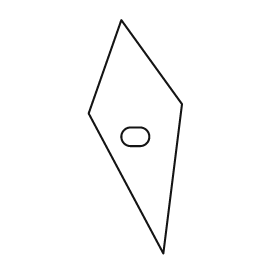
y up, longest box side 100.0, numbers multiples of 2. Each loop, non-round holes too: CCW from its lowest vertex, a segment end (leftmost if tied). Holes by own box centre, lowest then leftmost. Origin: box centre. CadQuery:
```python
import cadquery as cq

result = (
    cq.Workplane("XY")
    .moveTo(12.0, -50.0)
    .lineTo(20.0, 14.0)
    .lineTo(-6.0, 50.0)
    .lineTo(-20.0, 10.0)
    .close()
    .moveTo(-2.0, -4.0)
    .lineTo(2.0, -4.0)
    .threePointArc((6.0, 0.0), (2.0, 4.0))
    .lineTo(-2.0, 4.0)
    .threePointArc((-6.0, 0.0), (-2.0, -4.0))
    .close()
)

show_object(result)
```